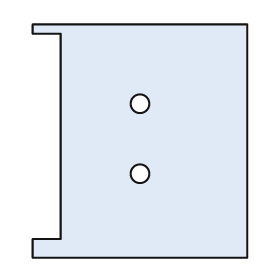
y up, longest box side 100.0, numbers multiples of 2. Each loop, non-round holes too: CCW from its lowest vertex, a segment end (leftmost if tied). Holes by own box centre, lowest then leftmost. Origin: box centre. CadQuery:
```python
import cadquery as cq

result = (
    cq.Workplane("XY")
    .moveTo(-46.0, -50.0)
    .lineTo(46.0, -50.0)
    .lineTo(46.0, 50.0)
    .lineTo(-46.0, 50.0)
    .lineTo(-46.0, 46.0)
    .lineTo(-34.0, 46.0)
    .lineTo(-34.0, -42.0)
    .lineTo(-46.0, -42.0)
    .close()
    .moveTo(0.0, -14.0)
    .circle(4.0)
    .moveTo(0.0, 16.0)
    .circle(4.0)
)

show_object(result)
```